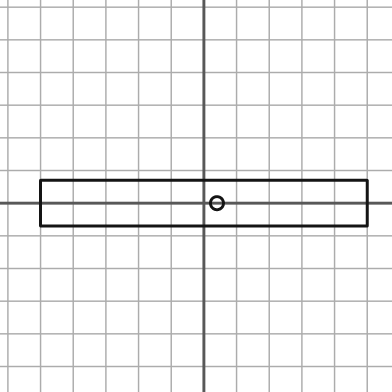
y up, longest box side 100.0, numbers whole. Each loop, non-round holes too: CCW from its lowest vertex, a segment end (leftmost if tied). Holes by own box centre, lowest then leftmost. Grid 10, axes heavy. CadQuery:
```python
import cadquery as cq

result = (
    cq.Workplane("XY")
    .moveTo(-50.0, -7.0)
    .lineTo(50.0, -7.0)
    .lineTo(50.0, 7.0)
    .lineTo(-50.0, 7.0)
    .close()
    .moveTo(4.0, 0.0)
    .circle(2.0)
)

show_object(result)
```